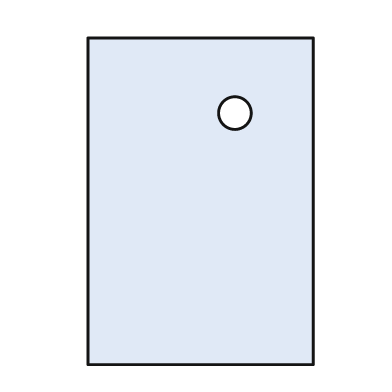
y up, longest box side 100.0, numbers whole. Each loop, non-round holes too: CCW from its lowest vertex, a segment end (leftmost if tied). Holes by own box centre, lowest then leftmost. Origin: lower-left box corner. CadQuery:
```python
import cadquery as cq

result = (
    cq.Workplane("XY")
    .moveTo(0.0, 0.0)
    .lineTo(69.0, 0.0)
    .lineTo(69.0, 100.0)
    .lineTo(0.0, 100.0)
    .close()
    .moveTo(45.0, 77.0)
    .circle(5.0)
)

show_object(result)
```